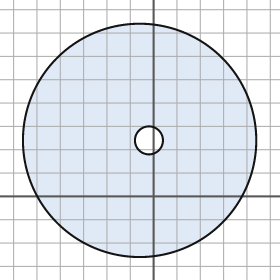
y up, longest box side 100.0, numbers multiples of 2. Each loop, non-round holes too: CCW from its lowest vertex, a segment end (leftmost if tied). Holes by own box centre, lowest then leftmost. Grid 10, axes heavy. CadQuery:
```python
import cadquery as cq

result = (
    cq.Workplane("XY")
    .moveTo(-6.0, 24.0)
    .circle(50.0)
    .moveTo(-2.0, 24.0)
    .circle(6.0)
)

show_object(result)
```